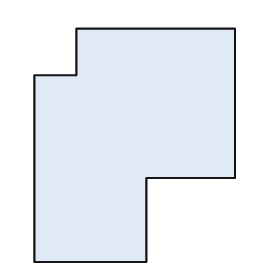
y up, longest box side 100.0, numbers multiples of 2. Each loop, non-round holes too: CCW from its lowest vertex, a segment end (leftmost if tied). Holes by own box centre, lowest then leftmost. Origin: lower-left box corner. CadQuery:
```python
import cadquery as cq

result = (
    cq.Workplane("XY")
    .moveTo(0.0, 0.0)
    .lineTo(48.0, 0.0)
    .lineTo(48.0, 36.0)
    .lineTo(86.0, 36.0)
    .lineTo(86.0, 100.0)
    .lineTo(18.0, 100.0)
    .lineTo(18.0, 80.0)
    .lineTo(0.0, 80.0)
    .close()
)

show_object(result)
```